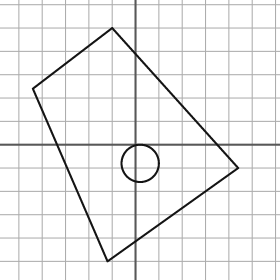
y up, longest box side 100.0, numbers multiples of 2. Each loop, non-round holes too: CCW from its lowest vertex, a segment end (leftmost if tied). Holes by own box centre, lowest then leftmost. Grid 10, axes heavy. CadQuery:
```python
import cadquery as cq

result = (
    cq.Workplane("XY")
    .moveTo(-12.0, -50.0)
    .lineTo(44.0, -10.0)
    .lineTo(-10.0, 50.0)
    .lineTo(-44.0, 24.0)
    .close()
    .moveTo(2.0, -8.0)
    .circle(8.0)
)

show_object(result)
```